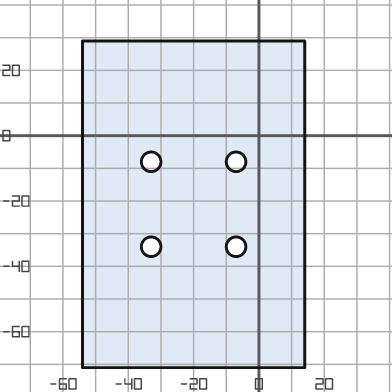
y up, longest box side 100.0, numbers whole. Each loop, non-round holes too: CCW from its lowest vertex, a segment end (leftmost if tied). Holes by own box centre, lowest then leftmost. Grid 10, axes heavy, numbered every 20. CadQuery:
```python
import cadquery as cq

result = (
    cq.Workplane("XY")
    .moveTo(-54.0, -71.0)
    .lineTo(14.0, -71.0)
    .lineTo(14.0, 29.0)
    .lineTo(-54.0, 29.0)
    .close()
    .moveTo(-33.0, -34.0)
    .circle(3.0)
    .moveTo(-7.0, -34.0)
    .circle(3.0)
    .moveTo(-33.0, -8.0)
    .circle(3.0)
    .moveTo(-7.0, -8.0)
    .circle(3.0)
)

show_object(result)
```